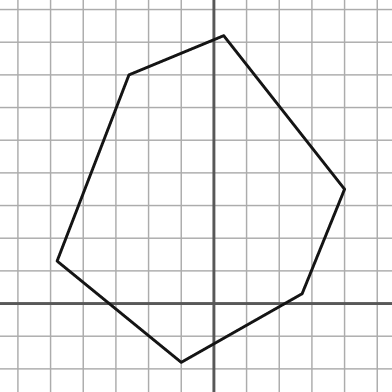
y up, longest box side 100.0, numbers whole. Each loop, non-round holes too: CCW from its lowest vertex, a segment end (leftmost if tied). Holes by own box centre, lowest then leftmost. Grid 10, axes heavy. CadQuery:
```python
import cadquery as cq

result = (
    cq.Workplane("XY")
    .moveTo(-10.0, -18.0)
    .lineTo(27.0, 3.0)
    .lineTo(40.0, 35.0)
    .lineTo(3.0, 82.0)
    .lineTo(-26.0, 70.0)
    .lineTo(-48.0, 13.0)
    .close()
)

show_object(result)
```